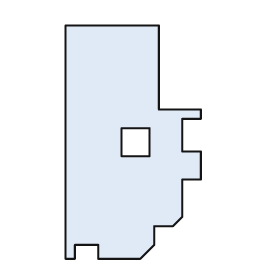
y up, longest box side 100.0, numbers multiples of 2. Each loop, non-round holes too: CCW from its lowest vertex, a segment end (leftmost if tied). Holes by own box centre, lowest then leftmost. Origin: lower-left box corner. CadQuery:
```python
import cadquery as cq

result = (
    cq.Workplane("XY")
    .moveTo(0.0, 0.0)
    .lineTo(4.0, 0.0)
    .lineTo(4.0, 6.0)
    .lineTo(14.0, 6.0)
    .lineTo(14.0, 0.0)
    .lineTo(32.0, 0.0)
    .lineTo(38.0, 6.0)
    .lineTo(38.0, 14.0)
    .lineTo(46.0, 14.0)
    .lineTo(50.0, 18.0)
    .lineTo(50.0, 34.0)
    .lineTo(58.0, 34.0)
    .lineTo(58.0, 46.0)
    .lineTo(50.0, 46.0)
    .lineTo(50.0, 60.0)
    .lineTo(58.0, 60.0)
    .lineTo(58.0, 64.0)
    .lineTo(40.0, 64.0)
    .lineTo(40.0, 100.0)
    .lineTo(0.0, 100.0)
    .close()
    .moveTo(24.0, 44.0)
    .lineTo(36.0, 44.0)
    .lineTo(36.0, 56.0)
    .lineTo(24.0, 56.0)
    .close()
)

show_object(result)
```